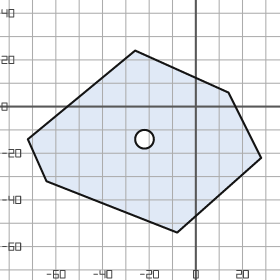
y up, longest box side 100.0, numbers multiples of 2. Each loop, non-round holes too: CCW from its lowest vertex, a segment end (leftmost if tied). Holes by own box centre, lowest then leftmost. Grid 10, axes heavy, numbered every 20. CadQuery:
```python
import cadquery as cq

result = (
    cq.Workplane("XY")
    .moveTo(-8.0, -54.0)
    .lineTo(28.0, -22.0)
    .lineTo(14.0, 6.0)
    .lineTo(-26.0, 24.0)
    .lineTo(-72.0, -14.0)
    .lineTo(-64.0, -32.0)
    .close()
    .moveTo(-22.0, -14.0)
    .circle(4.0)
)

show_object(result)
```